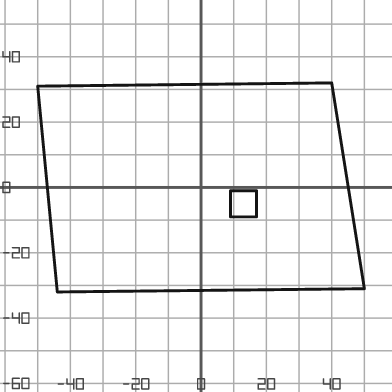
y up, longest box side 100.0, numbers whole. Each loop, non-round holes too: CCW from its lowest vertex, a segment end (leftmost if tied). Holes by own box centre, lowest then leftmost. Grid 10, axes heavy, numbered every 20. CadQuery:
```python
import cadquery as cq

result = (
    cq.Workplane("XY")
    .moveTo(-44.0, -32.0)
    .lineTo(50.0, -31.0)
    .lineTo(40.0, 32.0)
    .lineTo(-50.0, 31.0)
    .close()
    .moveTo(9.0, -9.0)
    .lineTo(17.0, -9.0)
    .lineTo(17.0, -1.0)
    .lineTo(9.0, -1.0)
    .close()
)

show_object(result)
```